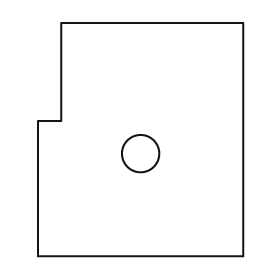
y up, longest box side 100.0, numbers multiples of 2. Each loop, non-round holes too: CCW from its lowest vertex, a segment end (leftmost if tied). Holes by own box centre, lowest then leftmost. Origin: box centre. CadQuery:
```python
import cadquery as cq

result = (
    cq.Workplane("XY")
    .moveTo(-44.0, -50.0)
    .lineTo(44.0, -50.0)
    .lineTo(44.0, 50.0)
    .lineTo(-34.0, 50.0)
    .lineTo(-34.0, 8.0)
    .lineTo(-44.0, 8.0)
    .close()
    .moveTo(0.0, -6.0)
    .circle(8.0)
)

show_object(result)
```